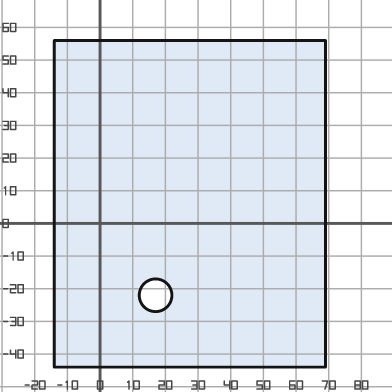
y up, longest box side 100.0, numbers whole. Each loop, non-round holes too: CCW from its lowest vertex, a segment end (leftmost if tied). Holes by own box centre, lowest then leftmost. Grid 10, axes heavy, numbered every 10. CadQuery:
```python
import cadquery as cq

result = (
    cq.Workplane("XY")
    .moveTo(-14.0, -44.0)
    .lineTo(69.0, -44.0)
    .lineTo(69.0, 56.0)
    .lineTo(-14.0, 56.0)
    .close()
    .moveTo(17.0, -22.0)
    .circle(5.0)
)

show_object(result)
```